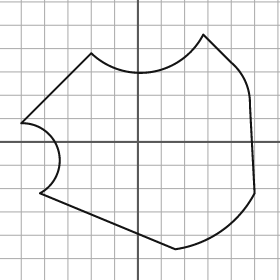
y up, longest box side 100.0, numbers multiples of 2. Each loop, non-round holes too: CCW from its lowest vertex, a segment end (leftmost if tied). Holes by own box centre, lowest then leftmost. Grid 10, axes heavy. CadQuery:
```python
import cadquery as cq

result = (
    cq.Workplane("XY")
    .moveTo(16.0, -46.0)
    .threePointArc((36.0, -38.0), (50.0, -22.0))
    .lineTo(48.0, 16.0)
    .threePointArc((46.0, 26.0), (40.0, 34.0))
    .lineTo(28.0, 46.0)
    .threePointArc((6.0, 30.0), (-20.0, 38.0))
    .lineTo(-50.0, 8.0)
    .threePointArc((-34.0, -4.0), (-42.0, -22.0))
    .close()
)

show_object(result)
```